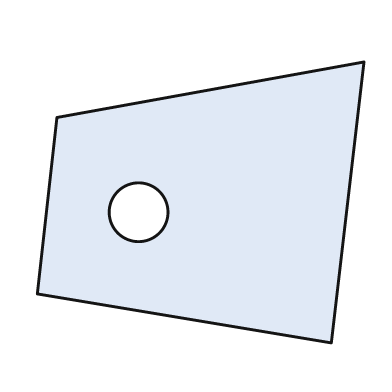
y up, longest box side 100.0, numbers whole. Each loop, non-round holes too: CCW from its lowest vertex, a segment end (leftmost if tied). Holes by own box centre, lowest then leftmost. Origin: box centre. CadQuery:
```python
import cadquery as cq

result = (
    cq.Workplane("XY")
    .moveTo(40.0, -43.0)
    .lineTo(50.0, 43.0)
    .lineTo(-44.0, 26.0)
    .lineTo(-50.0, -28.0)
    .close()
    .moveTo(-19.0, -3.0)
    .circle(9.0)
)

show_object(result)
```